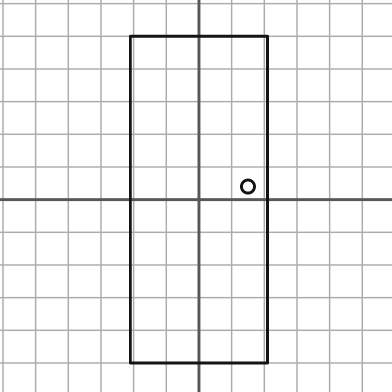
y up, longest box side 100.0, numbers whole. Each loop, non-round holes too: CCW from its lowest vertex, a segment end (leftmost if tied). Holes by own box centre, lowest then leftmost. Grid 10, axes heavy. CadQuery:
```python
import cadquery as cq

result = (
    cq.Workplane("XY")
    .moveTo(-21.0, -50.0)
    .lineTo(21.0, -50.0)
    .lineTo(21.0, 50.0)
    .lineTo(-21.0, 50.0)
    .close()
    .moveTo(15.0, 4.0)
    .circle(2.0)
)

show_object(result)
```